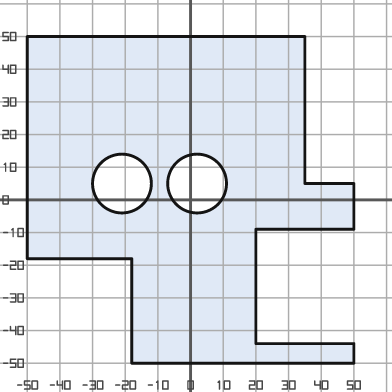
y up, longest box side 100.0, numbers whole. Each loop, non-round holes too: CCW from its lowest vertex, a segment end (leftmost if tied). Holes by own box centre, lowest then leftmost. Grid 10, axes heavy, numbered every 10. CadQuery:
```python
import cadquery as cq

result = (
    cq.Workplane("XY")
    .moveTo(-18.0, -50.0)
    .lineTo(50.0, -50.0)
    .lineTo(50.0, -44.0)
    .lineTo(20.0, -44.0)
    .lineTo(20.0, -9.0)
    .lineTo(50.0, -9.0)
    .lineTo(50.0, 5.0)
    .lineTo(35.0, 5.0)
    .lineTo(35.0, 50.0)
    .lineTo(-50.0, 50.0)
    .lineTo(-50.0, -18.0)
    .lineTo(-18.0, -18.0)
    .close()
    .moveTo(-21.0, 5.0)
    .circle(9.0)
    .moveTo(2.0, 5.0)
    .circle(9.0)
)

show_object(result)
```